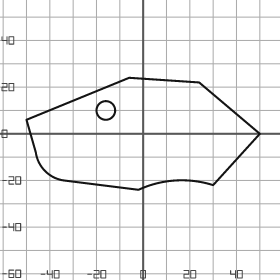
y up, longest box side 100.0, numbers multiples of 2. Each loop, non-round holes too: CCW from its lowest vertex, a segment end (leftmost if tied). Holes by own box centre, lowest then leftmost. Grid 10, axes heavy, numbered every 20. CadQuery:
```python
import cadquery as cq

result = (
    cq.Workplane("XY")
    .moveTo(-2.0, -24.0)
    .threePointArc((14.0, -20.0), (30.0, -22.0))
    .lineTo(50.0, 0.0)
    .lineTo(24.0, 22.0)
    .lineTo(-6.0, 24.0)
    .lineTo(-50.0, 6.0)
    .lineTo(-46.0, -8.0)
    .threePointArc((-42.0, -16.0), (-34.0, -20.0))
    .close()
    .moveTo(-16.0, 10.0)
    .circle(4.0)
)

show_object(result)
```